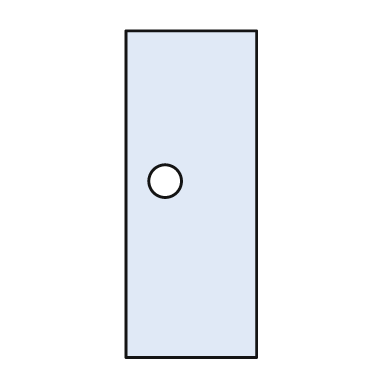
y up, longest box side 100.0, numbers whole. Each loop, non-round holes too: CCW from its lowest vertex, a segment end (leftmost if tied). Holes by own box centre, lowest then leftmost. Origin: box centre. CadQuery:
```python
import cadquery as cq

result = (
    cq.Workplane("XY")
    .moveTo(-20.0, -50.0)
    .lineTo(20.0, -50.0)
    .lineTo(20.0, 50.0)
    .lineTo(-20.0, 50.0)
    .close()
    .moveTo(-8.0, 4.0)
    .circle(5.0)
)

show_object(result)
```